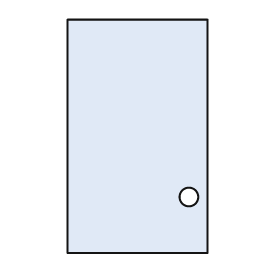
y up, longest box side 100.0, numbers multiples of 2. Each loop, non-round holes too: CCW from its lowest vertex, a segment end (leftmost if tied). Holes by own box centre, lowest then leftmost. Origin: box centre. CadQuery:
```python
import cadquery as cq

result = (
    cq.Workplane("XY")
    .moveTo(-30.0, -50.0)
    .lineTo(30.0, -50.0)
    .lineTo(30.0, 50.0)
    .lineTo(-30.0, 50.0)
    .close()
    .moveTo(22.0, -26.0)
    .circle(4.0)
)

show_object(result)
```